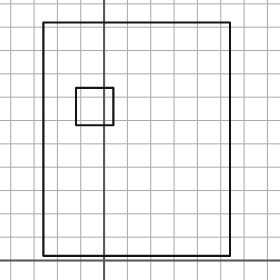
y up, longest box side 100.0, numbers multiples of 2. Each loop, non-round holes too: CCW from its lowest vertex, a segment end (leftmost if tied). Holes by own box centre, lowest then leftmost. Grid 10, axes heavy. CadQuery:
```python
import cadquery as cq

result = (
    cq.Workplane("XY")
    .moveTo(-26.0, 2.0)
    .lineTo(54.0, 2.0)
    .lineTo(54.0, 102.0)
    .lineTo(-26.0, 102.0)
    .close()
    .moveTo(-12.0, 58.0)
    .lineTo(4.0, 58.0)
    .lineTo(4.0, 74.0)
    .lineTo(-12.0, 74.0)
    .close()
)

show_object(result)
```